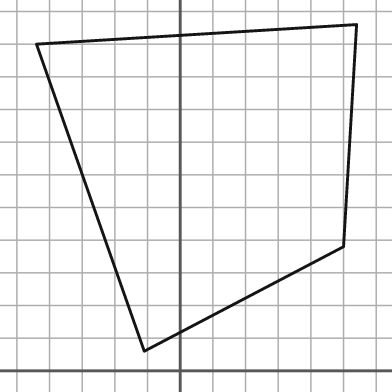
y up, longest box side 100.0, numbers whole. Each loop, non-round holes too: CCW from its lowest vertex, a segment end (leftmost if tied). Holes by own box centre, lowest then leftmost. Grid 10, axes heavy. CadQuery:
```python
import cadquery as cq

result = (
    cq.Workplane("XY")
    .moveTo(-11.0, 6.0)
    .lineTo(50.0, 38.0)
    .lineTo(54.0, 106.0)
    .lineTo(-44.0, 100.0)
    .close()
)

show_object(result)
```